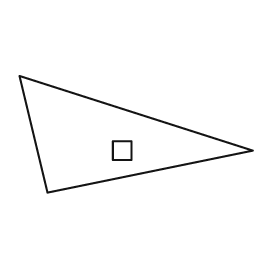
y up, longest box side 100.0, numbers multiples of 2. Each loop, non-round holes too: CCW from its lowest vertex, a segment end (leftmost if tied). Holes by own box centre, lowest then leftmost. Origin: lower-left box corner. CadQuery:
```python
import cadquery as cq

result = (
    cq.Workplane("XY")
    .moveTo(12.0, 0.0)
    .lineTo(100.0, 18.0)
    .lineTo(0.0, 50.0)
    .close()
    .moveTo(40.0, 14.0)
    .lineTo(48.0, 14.0)
    .lineTo(48.0, 22.0)
    .lineTo(40.0, 22.0)
    .close()
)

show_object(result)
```